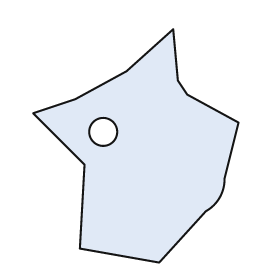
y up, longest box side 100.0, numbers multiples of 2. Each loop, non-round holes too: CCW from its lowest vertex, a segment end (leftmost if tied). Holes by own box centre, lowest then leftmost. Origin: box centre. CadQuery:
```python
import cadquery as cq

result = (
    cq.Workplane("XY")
    .moveTo(10.0, -50.0)
    .lineTo(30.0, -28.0)
    .threePointArc((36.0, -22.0), (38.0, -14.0))
    .lineTo(44.0, 10.0)
    .lineTo(22.0, 22.0)
    .lineTo(18.0, 28.0)
    .lineTo(16.0, 50.0)
    .lineTo(-4.0, 32.0)
    .lineTo(-26.0, 20.0)
    .lineTo(-44.0, 14.0)
    .lineTo(-22.0, -8.0)
    .lineTo(-24.0, -44.0)
    .close()
    .moveTo(-14.0, 6.0)
    .circle(6.0)
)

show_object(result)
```